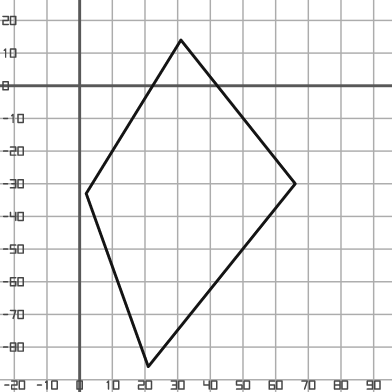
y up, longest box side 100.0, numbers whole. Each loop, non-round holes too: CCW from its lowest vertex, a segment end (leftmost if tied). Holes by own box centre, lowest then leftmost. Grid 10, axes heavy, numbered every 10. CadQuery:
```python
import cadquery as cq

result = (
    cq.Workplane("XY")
    .moveTo(21.0, -86.0)
    .lineTo(66.0, -30.0)
    .lineTo(31.0, 14.0)
    .lineTo(2.0, -33.0)
    .close()
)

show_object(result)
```